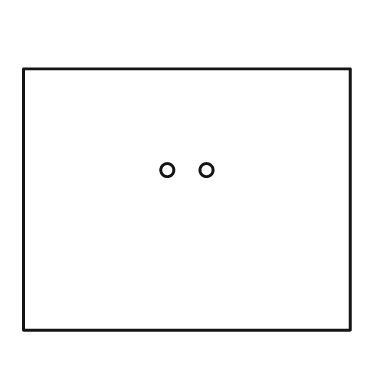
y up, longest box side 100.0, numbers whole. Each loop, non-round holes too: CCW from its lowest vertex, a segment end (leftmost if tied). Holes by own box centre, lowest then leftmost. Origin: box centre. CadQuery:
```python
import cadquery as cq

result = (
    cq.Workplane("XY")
    .moveTo(-50.0, -40.0)
    .lineTo(50.0, -40.0)
    .lineTo(50.0, 40.0)
    .lineTo(-50.0, 40.0)
    .close()
    .moveTo(-6.0, 9.0)
    .circle(2.0)
    .moveTo(6.0, 9.0)
    .circle(2.0)
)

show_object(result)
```